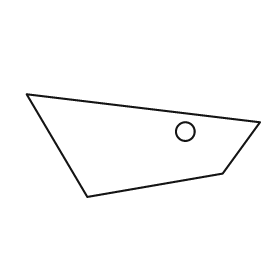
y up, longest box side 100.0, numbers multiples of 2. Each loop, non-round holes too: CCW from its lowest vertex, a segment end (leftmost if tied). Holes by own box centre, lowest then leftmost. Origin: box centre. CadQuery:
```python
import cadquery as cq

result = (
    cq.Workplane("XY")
    .moveTo(-24.0, -22.0)
    .lineTo(34.0, -12.0)
    .lineTo(50.0, 10.0)
    .lineTo(-50.0, 22.0)
    .close()
    .moveTo(18.0, 6.0)
    .circle(4.0)
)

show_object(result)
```